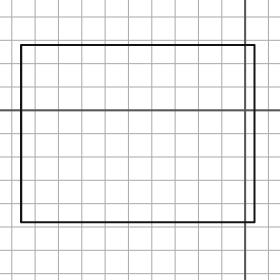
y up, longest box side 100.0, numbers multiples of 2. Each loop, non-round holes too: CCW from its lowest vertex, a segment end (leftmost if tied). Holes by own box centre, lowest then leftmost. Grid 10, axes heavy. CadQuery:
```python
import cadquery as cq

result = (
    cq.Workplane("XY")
    .moveTo(-96.0, -48.0)
    .lineTo(4.0, -48.0)
    .lineTo(4.0, 28.0)
    .lineTo(-96.0, 28.0)
    .close()
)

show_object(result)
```